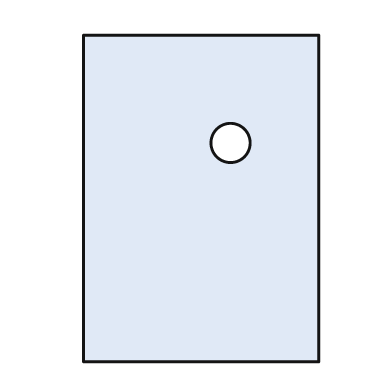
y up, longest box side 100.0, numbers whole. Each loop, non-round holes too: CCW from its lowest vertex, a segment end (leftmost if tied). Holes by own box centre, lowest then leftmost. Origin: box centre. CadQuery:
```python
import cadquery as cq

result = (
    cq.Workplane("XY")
    .moveTo(-36.0, -50.0)
    .lineTo(36.0, -50.0)
    .lineTo(36.0, 50.0)
    .lineTo(-36.0, 50.0)
    .close()
    .moveTo(9.0, 17.0)
    .circle(6.0)
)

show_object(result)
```